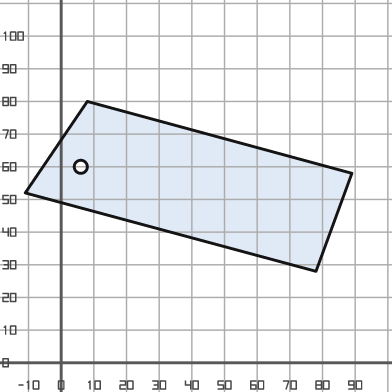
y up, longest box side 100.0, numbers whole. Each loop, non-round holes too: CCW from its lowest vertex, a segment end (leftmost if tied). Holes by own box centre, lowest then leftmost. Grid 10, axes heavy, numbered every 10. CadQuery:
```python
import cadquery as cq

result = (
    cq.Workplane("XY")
    .moveTo(78.0, 28.0)
    .lineTo(89.0, 58.0)
    .lineTo(8.0, 80.0)
    .lineTo(-11.0, 52.0)
    .close()
    .moveTo(6.0, 60.0)
    .circle(2.0)
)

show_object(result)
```